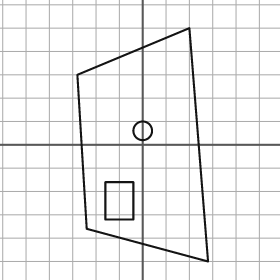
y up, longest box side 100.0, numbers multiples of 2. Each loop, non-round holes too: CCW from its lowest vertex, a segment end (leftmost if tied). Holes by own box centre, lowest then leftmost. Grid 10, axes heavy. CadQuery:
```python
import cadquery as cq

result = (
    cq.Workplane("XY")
    .moveTo(28.0, -50.0)
    .lineTo(20.0, 50.0)
    .lineTo(-28.0, 30.0)
    .lineTo(-24.0, -36.0)
    .close()
    .moveTo(-16.0, -32.0)
    .lineTo(-4.0, -32.0)
    .lineTo(-4.0, -16.0)
    .lineTo(-16.0, -16.0)
    .close()
    .moveTo(0.0, 6.0)
    .circle(4.0)
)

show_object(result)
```